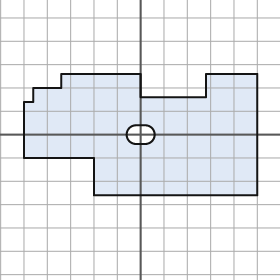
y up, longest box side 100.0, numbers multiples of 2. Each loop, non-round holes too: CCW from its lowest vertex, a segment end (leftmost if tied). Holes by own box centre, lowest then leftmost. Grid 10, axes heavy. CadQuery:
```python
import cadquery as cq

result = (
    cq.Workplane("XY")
    .moveTo(-20.0, -26.0)
    .lineTo(50.0, -26.0)
    .lineTo(50.0, 26.0)
    .lineTo(28.0, 26.0)
    .lineTo(28.0, 16.0)
    .lineTo(0.0, 16.0)
    .lineTo(0.0, 26.0)
    .lineTo(-34.0, 26.0)
    .lineTo(-34.0, 20.0)
    .lineTo(-46.0, 20.0)
    .lineTo(-46.0, 14.0)
    .lineTo(-50.0, 14.0)
    .lineTo(-50.0, -10.0)
    .lineTo(-20.0, -10.0)
    .close()
    .moveTo(-2.0, -4.0)
    .lineTo(2.0, -4.0)
    .threePointArc((6.0, 0.0), (2.0, 4.0))
    .lineTo(-2.0, 4.0)
    .threePointArc((-6.0, 0.0), (-2.0, -4.0))
    .close()
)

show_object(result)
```